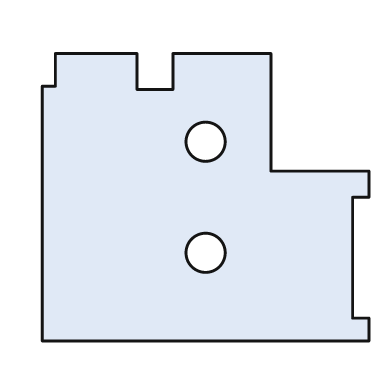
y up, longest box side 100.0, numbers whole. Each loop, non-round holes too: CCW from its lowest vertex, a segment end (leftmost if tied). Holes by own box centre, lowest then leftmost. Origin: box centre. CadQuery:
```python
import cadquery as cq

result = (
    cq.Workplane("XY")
    .moveTo(-50.0, -44.0)
    .lineTo(50.0, -44.0)
    .lineTo(50.0, -37.0)
    .lineTo(45.0, -37.0)
    .lineTo(45.0, 0.0)
    .lineTo(50.0, 0.0)
    .lineTo(50.0, 8.0)
    .lineTo(20.0, 8.0)
    .lineTo(20.0, 44.0)
    .lineTo(-10.0, 44.0)
    .lineTo(-10.0, 33.0)
    .lineTo(-21.0, 33.0)
    .lineTo(-21.0, 44.0)
    .lineTo(-46.0, 44.0)
    .lineTo(-46.0, 34.0)
    .lineTo(-50.0, 34.0)
    .close()
    .moveTo(0.0, -17.0)
    .circle(6.0)
    .moveTo(0.0, 17.0)
    .circle(6.0)
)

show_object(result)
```